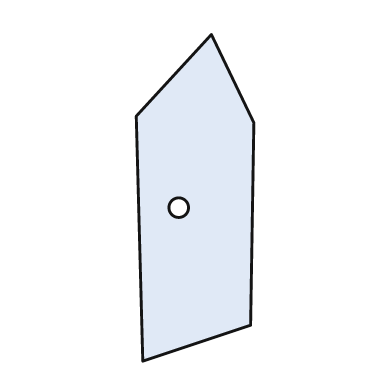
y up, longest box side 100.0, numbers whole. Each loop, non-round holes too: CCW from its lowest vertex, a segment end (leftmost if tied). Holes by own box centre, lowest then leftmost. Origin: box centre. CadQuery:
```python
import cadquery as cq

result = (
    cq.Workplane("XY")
    .moveTo(-16.0, -50.0)
    .lineTo(17.0, -39.0)
    .lineTo(18.0, 23.0)
    .lineTo(5.0, 50.0)
    .lineTo(-18.0, 25.0)
    .close()
    .moveTo(-5.0, -3.0)
    .circle(3.0)
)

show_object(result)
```